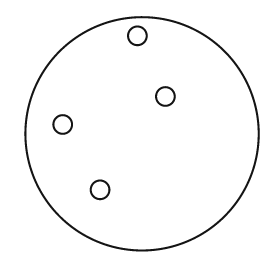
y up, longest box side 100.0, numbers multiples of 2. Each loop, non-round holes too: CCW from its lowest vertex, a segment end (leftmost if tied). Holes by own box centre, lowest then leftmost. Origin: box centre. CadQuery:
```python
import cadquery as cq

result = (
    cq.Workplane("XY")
    .moveTo(0.0, 0.0)
    .circle(50.0)
    .moveTo(-18.0, -24.0)
    .circle(4.0)
    .moveTo(-34.0, 4.0)
    .circle(4.0)
    .moveTo(10.0, 16.0)
    .circle(4.0)
    .moveTo(-2.0, 42.0)
    .circle(4.0)
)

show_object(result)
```